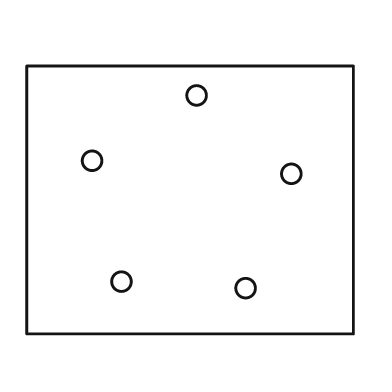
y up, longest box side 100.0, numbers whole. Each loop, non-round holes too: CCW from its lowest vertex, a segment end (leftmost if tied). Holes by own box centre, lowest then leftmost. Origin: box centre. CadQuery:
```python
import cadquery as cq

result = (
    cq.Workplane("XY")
    .moveTo(-50.0, -41.0)
    .lineTo(50.0, -41.0)
    .lineTo(50.0, 41.0)
    .lineTo(-50.0, 41.0)
    .close()
    .moveTo(17.0, -27.0)
    .circle(3.0)
    .moveTo(-21.0, -25.0)
    .circle(3.0)
    .moveTo(31.0, 8.0)
    .circle(3.0)
    .moveTo(-30.0, 12.0)
    .circle(3.0)
    .moveTo(2.0, 32.0)
    .circle(3.0)
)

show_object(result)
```